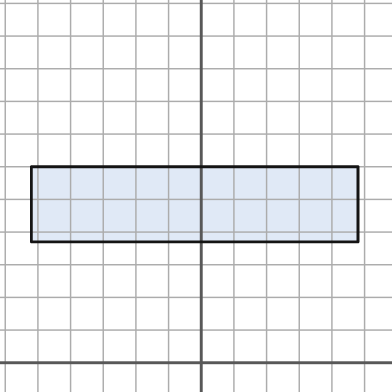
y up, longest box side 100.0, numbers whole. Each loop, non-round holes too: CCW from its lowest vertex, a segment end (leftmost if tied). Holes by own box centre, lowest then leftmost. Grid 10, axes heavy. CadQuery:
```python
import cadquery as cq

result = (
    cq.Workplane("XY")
    .moveTo(-52.0, 37.0)
    .lineTo(48.0, 37.0)
    .lineTo(48.0, 60.0)
    .lineTo(-52.0, 60.0)
    .close()
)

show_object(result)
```